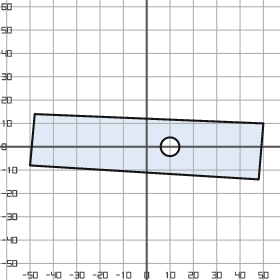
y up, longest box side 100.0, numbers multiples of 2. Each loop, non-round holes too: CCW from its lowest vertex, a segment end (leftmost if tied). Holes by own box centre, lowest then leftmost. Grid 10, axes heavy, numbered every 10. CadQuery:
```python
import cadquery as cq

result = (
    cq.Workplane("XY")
    .moveTo(48.0, -14.0)
    .lineTo(50.0, 10.0)
    .lineTo(-48.0, 14.0)
    .lineTo(-50.0, -8.0)
    .close()
    .moveTo(10.0, 0.0)
    .circle(4.0)
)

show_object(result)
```